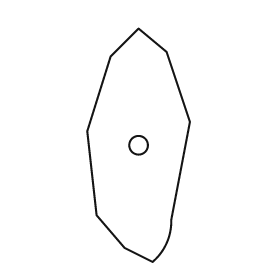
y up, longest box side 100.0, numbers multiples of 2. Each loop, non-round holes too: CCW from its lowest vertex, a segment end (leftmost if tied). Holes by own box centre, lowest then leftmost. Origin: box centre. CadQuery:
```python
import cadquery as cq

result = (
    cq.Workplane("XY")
    .moveTo(6.0, -50.0)
    .threePointArc((12.0, -42.0), (14.0, -32.0))
    .lineTo(22.0, 10.0)
    .lineTo(12.0, 40.0)
    .lineTo(0.0, 50.0)
    .lineTo(-12.0, 38.0)
    .lineTo(-22.0, 6.0)
    .lineTo(-18.0, -30.0)
    .lineTo(-6.0, -44.0)
    .close()
    .moveTo(0.0, 0.0)
    .circle(4.0)
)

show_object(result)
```